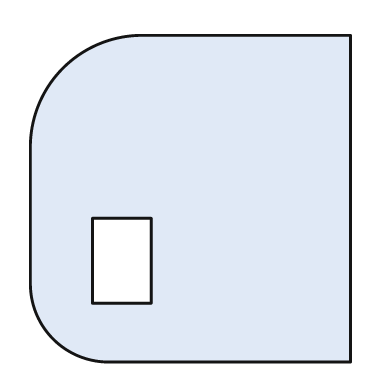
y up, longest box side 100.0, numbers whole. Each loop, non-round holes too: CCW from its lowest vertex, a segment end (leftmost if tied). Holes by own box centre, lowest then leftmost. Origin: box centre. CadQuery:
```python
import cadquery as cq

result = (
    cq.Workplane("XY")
    .moveTo(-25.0, -50.0)
    .lineTo(49.0, -50.0)
    .lineTo(49.0, 50.0)
    .lineTo(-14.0, 50.0)
    .threePointArc((-39.0, 40.0), (-49.0, 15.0))
    .lineTo(-49.0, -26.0)
    .threePointArc((-42.0, -43.0), (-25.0, -50.0))
    .close()
    .moveTo(-30.0, -32.0)
    .lineTo(-12.0, -32.0)
    .lineTo(-12.0, -6.0)
    .lineTo(-30.0, -6.0)
    .close()
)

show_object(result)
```